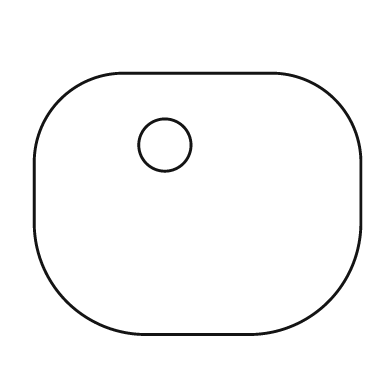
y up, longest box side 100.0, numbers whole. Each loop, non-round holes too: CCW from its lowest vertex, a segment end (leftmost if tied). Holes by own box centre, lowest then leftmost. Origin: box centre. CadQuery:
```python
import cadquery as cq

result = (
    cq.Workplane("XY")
    .moveTo(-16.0, -40.0)
    .lineTo(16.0, -40.0)
    .threePointArc((40.0, -30.0), (50.0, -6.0))
    .lineTo(50.0, 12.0)
    .threePointArc((42.0, 32.0), (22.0, 40.0))
    .lineTo(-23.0, 40.0)
    .threePointArc((-42.0, 32.0), (-50.0, 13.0))
    .lineTo(-50.0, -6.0)
    .threePointArc((-40.0, -30.0), (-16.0, -40.0))
    .close()
    .moveTo(-10.0, 18.0)
    .circle(8.0)
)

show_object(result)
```